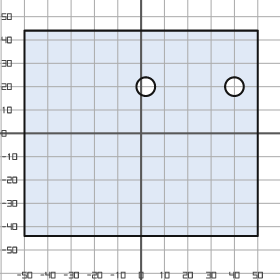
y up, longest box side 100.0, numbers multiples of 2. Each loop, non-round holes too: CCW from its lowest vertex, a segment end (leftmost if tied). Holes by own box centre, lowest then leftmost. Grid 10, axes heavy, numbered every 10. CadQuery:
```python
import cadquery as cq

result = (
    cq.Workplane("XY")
    .moveTo(-50.0, -44.0)
    .lineTo(50.0, -44.0)
    .lineTo(50.0, 44.0)
    .lineTo(-50.0, 44.0)
    .close()
    .moveTo(2.0, 20.0)
    .circle(4.0)
    .moveTo(40.0, 20.0)
    .circle(4.0)
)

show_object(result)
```